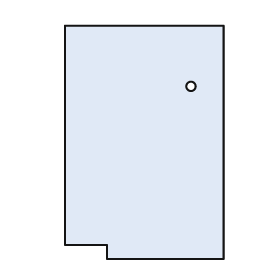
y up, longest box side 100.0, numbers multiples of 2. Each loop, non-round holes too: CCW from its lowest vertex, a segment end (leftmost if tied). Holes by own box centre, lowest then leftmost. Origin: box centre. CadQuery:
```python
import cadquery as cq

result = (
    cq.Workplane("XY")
    .moveTo(-16.0, -50.0)
    .lineTo(34.0, -50.0)
    .lineTo(34.0, 50.0)
    .lineTo(-34.0, 50.0)
    .lineTo(-34.0, -44.0)
    .lineTo(-16.0, -44.0)
    .close()
    .moveTo(20.0, 24.0)
    .circle(2.0)
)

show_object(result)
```